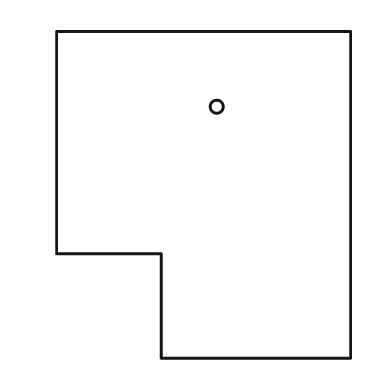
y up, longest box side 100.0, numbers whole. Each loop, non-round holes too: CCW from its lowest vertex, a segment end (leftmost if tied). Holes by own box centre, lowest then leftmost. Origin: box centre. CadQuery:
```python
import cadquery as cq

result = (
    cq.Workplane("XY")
    .moveTo(-13.0, -50.0)
    .lineTo(45.0, -50.0)
    .lineTo(45.0, 50.0)
    .lineTo(-45.0, 50.0)
    .lineTo(-45.0, -18.0)
    .lineTo(-13.0, -18.0)
    .close()
    .moveTo(4.0, 27.0)
    .circle(2.0)
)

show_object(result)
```